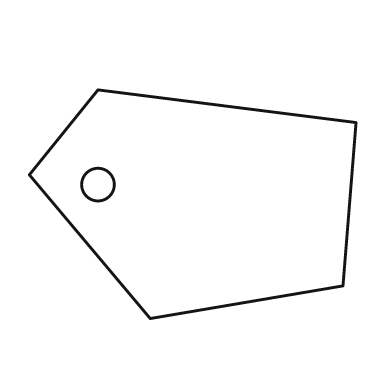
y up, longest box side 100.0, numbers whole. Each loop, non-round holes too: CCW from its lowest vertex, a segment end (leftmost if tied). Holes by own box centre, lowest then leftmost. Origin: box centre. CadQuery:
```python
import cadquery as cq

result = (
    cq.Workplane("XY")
    .moveTo(-13.0, -35.0)
    .lineTo(46.0, -25.0)
    .lineTo(50.0, 25.0)
    .lineTo(-29.0, 35.0)
    .lineTo(-50.0, 9.0)
    .close()
    .moveTo(-29.0, 6.0)
    .circle(5.0)
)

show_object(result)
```